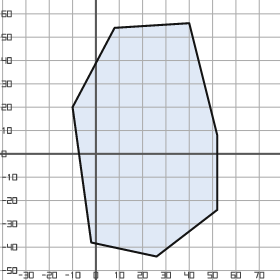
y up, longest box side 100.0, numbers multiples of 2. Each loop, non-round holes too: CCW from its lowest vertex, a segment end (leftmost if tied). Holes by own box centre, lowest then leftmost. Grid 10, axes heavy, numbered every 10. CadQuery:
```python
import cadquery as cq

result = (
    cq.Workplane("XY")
    .moveTo(26.0, -44.0)
    .lineTo(52.0, -24.0)
    .lineTo(52.0, 8.0)
    .lineTo(40.0, 56.0)
    .lineTo(8.0, 54.0)
    .lineTo(-10.0, 20.0)
    .lineTo(-2.0, -38.0)
    .close()
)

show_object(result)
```